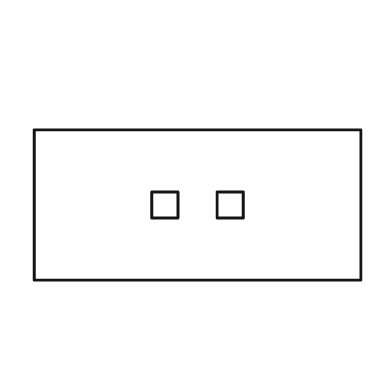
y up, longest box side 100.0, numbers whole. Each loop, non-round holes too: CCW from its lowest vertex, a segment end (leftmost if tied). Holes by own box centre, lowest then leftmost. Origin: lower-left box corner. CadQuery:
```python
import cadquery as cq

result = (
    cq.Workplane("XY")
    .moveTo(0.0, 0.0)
    .lineTo(100.0, 0.0)
    .lineTo(100.0, 46.0)
    .lineTo(0.0, 46.0)
    .close()
    .moveTo(36.0, 19.0)
    .lineTo(44.0, 19.0)
    .lineTo(44.0, 27.0)
    .lineTo(36.0, 27.0)
    .close()
    .moveTo(56.0, 19.0)
    .lineTo(64.0, 19.0)
    .lineTo(64.0, 27.0)
    .lineTo(56.0, 27.0)
    .close()
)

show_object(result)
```